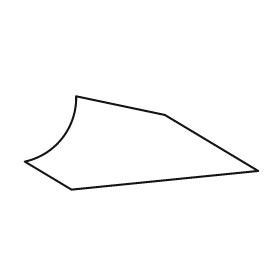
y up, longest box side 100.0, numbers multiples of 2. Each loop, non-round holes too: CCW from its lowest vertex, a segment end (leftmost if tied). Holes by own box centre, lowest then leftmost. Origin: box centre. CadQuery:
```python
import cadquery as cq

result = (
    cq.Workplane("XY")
    .moveTo(-30.0, -20.0)
    .lineTo(50.0, -12.0)
    .lineTo(10.0, 12.0)
    .lineTo(-28.0, 20.0)
    .threePointArc((-34.0, 2.0), (-50.0, -8.0))
    .close()
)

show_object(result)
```